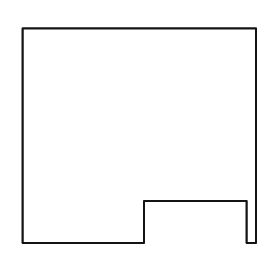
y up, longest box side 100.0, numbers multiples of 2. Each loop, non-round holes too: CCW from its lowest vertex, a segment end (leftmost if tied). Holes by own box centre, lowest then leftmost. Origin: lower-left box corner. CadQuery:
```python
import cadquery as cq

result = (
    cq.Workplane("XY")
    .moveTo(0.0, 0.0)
    .lineTo(52.0, 0.0)
    .lineTo(52.0, 18.0)
    .lineTo(96.0, 18.0)
    .lineTo(96.0, 0.0)
    .lineTo(100.0, 0.0)
    .lineTo(100.0, 92.0)
    .lineTo(0.0, 92.0)
    .close()
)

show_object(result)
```